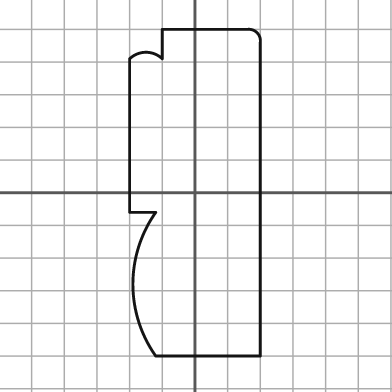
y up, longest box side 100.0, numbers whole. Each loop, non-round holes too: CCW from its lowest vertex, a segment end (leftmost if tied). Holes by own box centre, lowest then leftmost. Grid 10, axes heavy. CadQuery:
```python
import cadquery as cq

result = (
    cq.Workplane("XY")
    .moveTo(-12.0, -50.0)
    .lineTo(20.0, -50.0)
    .lineTo(20.0, 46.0)
    .threePointArc((19.0, 49.0), (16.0, 50.0))
    .lineTo(-10.0, 50.0)
    .lineTo(-10.0, 41.0)
    .threePointArc((-15.0, 43.0), (-20.0, 41.0))
    .lineTo(-20.0, -6.0)
    .lineTo(-12.0, -6.0)
    .threePointArc((-19.0, -28.0), (-12.0, -50.0))
    .close()
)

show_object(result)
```